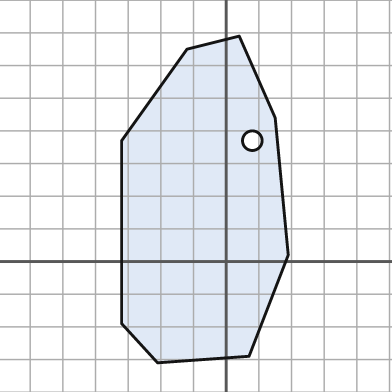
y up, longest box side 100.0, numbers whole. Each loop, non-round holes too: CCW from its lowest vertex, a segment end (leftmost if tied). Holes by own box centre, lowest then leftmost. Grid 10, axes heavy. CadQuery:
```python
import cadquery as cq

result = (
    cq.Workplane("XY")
    .moveTo(-21.0, -31.0)
    .lineTo(7.0, -29.0)
    .lineTo(19.0, 2.0)
    .lineTo(15.0, 44.0)
    .lineTo(4.0, 69.0)
    .lineTo(-12.0, 65.0)
    .lineTo(-32.0, 37.0)
    .lineTo(-32.0, -19.0)
    .close()
    .moveTo(8.0, 37.0)
    .circle(3.0)
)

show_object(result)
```